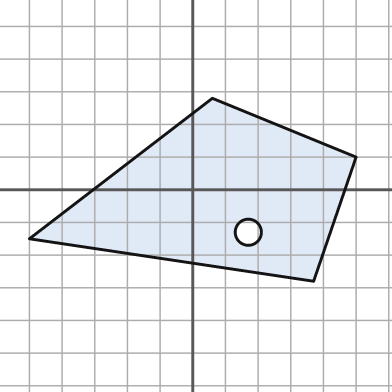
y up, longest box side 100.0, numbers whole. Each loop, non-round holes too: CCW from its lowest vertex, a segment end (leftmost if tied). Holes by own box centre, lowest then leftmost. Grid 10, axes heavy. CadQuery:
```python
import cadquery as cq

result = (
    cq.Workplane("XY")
    .moveTo(37.0, -28.0)
    .lineTo(50.0, 10.0)
    .lineTo(6.0, 28.0)
    .lineTo(-50.0, -15.0)
    .close()
    .moveTo(17.0, -13.0)
    .circle(4.0)
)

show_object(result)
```